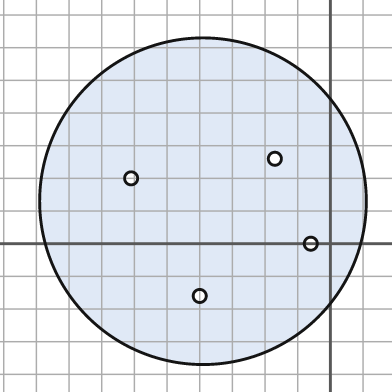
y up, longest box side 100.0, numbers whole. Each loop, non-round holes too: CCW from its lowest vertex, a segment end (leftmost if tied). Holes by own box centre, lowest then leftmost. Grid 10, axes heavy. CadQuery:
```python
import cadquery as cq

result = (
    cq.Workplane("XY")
    .moveTo(-39.0, 13.0)
    .circle(50.0)
    .moveTo(-40.0, -16.0)
    .circle(2.0)
    .moveTo(-6.0, 0.0)
    .circle(2.0)
    .moveTo(-61.0, 20.0)
    .circle(2.0)
    .moveTo(-17.0, 26.0)
    .circle(2.0)
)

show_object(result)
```